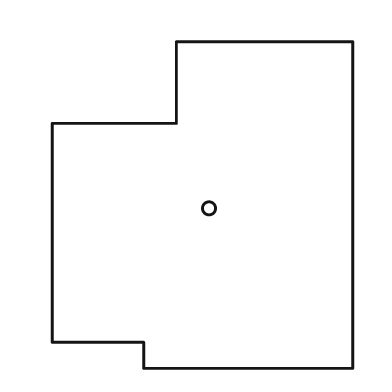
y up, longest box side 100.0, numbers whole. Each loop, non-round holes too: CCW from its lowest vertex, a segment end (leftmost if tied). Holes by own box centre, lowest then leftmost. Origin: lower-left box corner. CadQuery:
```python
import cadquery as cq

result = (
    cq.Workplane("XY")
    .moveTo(28.0, 0.0)
    .lineTo(92.0, 0.0)
    .lineTo(92.0, 100.0)
    .lineTo(38.0, 100.0)
    .lineTo(38.0, 75.0)
    .lineTo(0.0, 75.0)
    .lineTo(0.0, 8.0)
    .lineTo(28.0, 8.0)
    .close()
    .moveTo(48.0, 49.0)
    .circle(2.0)
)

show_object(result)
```